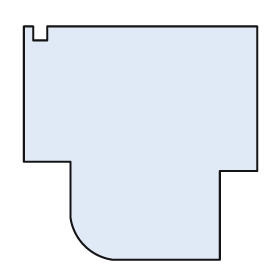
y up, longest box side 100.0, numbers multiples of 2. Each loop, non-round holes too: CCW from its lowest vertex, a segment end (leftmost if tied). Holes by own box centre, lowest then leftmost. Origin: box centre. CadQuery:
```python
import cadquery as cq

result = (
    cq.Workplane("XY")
    .moveTo(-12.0, -50.0)
    .lineTo(34.0, -50.0)
    .lineTo(34.0, -12.0)
    .lineTo(50.0, -12.0)
    .lineTo(50.0, 50.0)
    .lineTo(-40.0, 50.0)
    .lineTo(-40.0, 44.0)
    .lineTo(-46.0, 44.0)
    .lineTo(-46.0, 50.0)
    .lineTo(-50.0, 50.0)
    .lineTo(-50.0, -8.0)
    .lineTo(-30.0, -8.0)
    .lineTo(-30.0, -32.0)
    .threePointArc((-24.0, -44.0), (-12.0, -50.0))
    .close()
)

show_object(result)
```